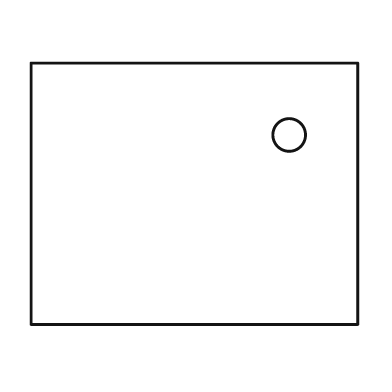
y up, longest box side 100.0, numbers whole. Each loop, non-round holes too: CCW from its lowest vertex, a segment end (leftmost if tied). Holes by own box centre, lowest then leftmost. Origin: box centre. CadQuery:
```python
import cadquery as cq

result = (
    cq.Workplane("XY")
    .moveTo(-50.0, -40.0)
    .lineTo(50.0, -40.0)
    .lineTo(50.0, 40.0)
    .lineTo(-50.0, 40.0)
    .close()
    .moveTo(29.0, 18.0)
    .circle(5.0)
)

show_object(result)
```